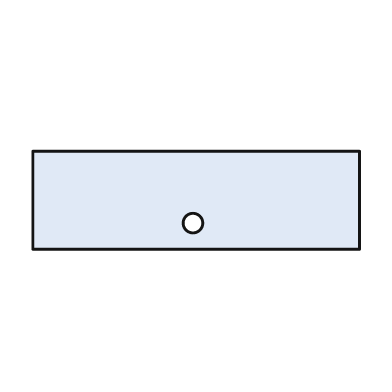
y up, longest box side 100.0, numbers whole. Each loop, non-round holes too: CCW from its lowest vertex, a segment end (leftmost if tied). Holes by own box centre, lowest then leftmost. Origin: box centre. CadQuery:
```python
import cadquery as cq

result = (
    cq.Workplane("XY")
    .moveTo(-50.0, -15.0)
    .lineTo(50.0, -15.0)
    .lineTo(50.0, 15.0)
    .lineTo(-50.0, 15.0)
    .close()
    .moveTo(-1.0, -7.0)
    .circle(3.0)
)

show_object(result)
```